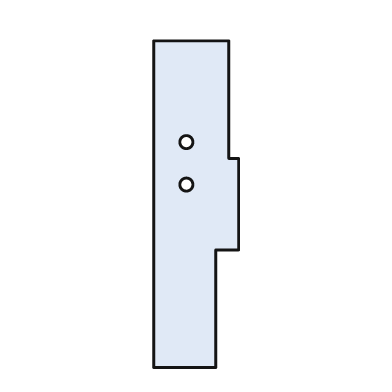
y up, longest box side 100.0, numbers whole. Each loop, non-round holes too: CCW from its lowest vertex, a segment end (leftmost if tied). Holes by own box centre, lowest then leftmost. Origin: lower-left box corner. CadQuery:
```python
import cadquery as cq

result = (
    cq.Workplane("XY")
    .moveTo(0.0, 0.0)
    .lineTo(19.0, 0.0)
    .lineTo(19.0, 36.0)
    .lineTo(26.0, 36.0)
    .lineTo(26.0, 64.0)
    .lineTo(23.0, 64.0)
    .lineTo(23.0, 100.0)
    .lineTo(0.0, 100.0)
    .close()
    .moveTo(10.0, 56.0)
    .circle(2.0)
    .moveTo(10.0, 69.0)
    .circle(2.0)
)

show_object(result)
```